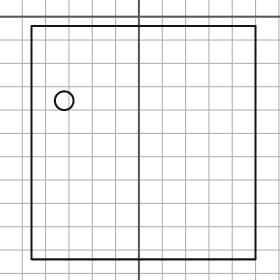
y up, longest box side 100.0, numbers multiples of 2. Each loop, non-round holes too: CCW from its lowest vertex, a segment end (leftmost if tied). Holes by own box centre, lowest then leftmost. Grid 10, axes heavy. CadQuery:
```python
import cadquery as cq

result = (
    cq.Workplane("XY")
    .moveTo(-46.0, -104.0)
    .lineTo(50.0, -104.0)
    .lineTo(50.0, -4.0)
    .lineTo(-46.0, -4.0)
    .close()
    .moveTo(-32.0, -36.0)
    .circle(4.0)
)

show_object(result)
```